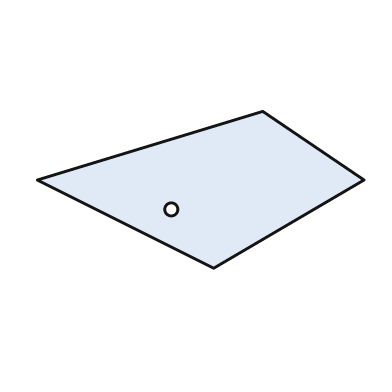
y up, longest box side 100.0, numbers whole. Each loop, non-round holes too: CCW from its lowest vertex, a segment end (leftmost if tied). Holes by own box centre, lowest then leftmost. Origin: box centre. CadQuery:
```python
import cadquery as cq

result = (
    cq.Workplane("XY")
    .moveTo(4.0, -24.0)
    .lineTo(50.0, 3.0)
    .lineTo(19.0, 24.0)
    .lineTo(-50.0, 3.0)
    .close()
    .moveTo(-9.0, -6.0)
    .circle(2.0)
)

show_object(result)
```